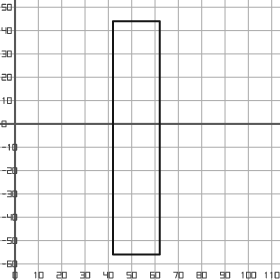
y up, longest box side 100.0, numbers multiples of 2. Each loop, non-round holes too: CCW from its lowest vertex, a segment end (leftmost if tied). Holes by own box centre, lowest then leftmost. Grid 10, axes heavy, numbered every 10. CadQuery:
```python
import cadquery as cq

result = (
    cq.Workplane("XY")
    .moveTo(42.0, -56.0)
    .lineTo(62.0, -56.0)
    .lineTo(62.0, 44.0)
    .lineTo(42.0, 44.0)
    .close()
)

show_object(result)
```